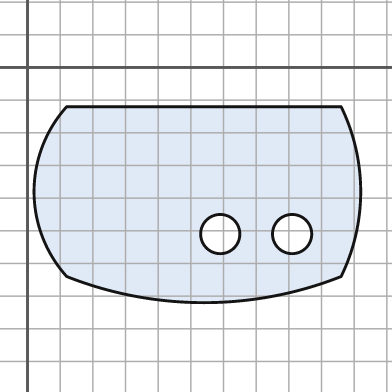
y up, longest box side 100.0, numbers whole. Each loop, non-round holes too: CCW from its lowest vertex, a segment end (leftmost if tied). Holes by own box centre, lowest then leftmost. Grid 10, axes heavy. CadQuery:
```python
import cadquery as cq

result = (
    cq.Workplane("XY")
    .moveTo(12.0, -64.0)
    .threePointArc((54.0, -72.0), (96.0, -64.0))
    .threePointArc((102.0, -38.0), (96.0, -12.0))
    .lineTo(12.0, -12.0)
    .threePointArc((2.0, -38.0), (12.0, -64.0))
    .close()
    .moveTo(59.0, -51.0)
    .circle(6.0)
    .moveTo(81.0, -51.0)
    .circle(6.0)
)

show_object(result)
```